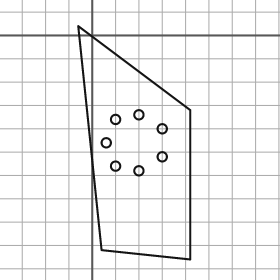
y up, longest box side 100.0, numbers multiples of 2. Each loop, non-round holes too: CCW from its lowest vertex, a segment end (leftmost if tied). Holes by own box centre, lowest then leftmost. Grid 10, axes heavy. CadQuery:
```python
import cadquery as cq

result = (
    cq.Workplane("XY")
    .moveTo(42.0, -96.0)
    .lineTo(42.0, -32.0)
    .lineTo(-6.0, 4.0)
    .lineTo(4.0, -92.0)
    .close()
    .moveTo(20.0, -58.0)
    .circle(2.0)
    .moveTo(10.0, -56.0)
    .circle(2.0)
    .moveTo(30.0, -52.0)
    .circle(2.0)
    .moveTo(6.0, -46.0)
    .circle(2.0)
    .moveTo(30.0, -40.0)
    .circle(2.0)
    .moveTo(10.0, -36.0)
    .circle(2.0)
    .moveTo(20.0, -34.0)
    .circle(2.0)
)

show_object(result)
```